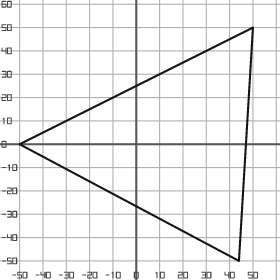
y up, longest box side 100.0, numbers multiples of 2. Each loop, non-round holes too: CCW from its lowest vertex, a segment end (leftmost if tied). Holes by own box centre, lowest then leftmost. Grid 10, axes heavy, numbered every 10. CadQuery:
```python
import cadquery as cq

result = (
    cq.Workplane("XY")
    .moveTo(44.0, -50.0)
    .lineTo(50.0, 50.0)
    .lineTo(-50.0, 0.0)
    .close()
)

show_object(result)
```